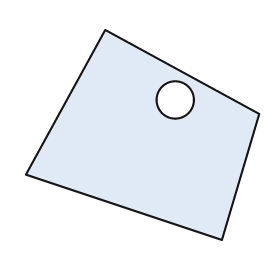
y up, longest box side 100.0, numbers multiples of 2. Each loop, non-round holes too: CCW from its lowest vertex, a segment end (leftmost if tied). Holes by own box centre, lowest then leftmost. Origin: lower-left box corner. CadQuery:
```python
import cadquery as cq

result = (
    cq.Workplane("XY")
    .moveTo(84.0, 0.0)
    .lineTo(100.0, 54.0)
    .lineTo(34.0, 90.0)
    .lineTo(0.0, 28.0)
    .close()
    .moveTo(64.0, 60.0)
    .circle(8.0)
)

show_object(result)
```